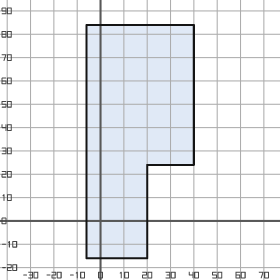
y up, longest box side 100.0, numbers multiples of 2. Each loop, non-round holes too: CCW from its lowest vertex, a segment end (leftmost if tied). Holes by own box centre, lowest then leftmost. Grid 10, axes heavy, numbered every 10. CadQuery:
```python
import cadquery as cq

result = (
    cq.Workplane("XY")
    .moveTo(-6.0, -16.0)
    .lineTo(20.0, -16.0)
    .lineTo(20.0, 24.0)
    .lineTo(40.0, 24.0)
    .lineTo(40.0, 84.0)
    .lineTo(-6.0, 84.0)
    .close()
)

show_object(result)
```